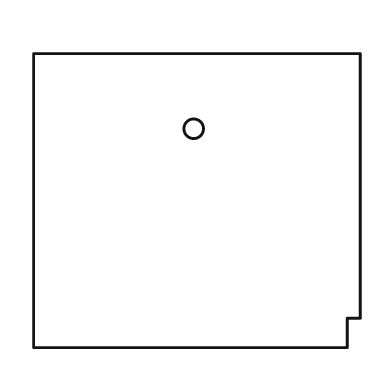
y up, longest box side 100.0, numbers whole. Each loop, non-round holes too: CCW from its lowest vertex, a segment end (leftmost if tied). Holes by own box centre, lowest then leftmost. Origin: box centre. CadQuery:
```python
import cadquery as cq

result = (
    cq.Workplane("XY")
    .moveTo(-50.0, -45.0)
    .lineTo(46.0, -45.0)
    .lineTo(46.0, -36.0)
    .lineTo(50.0, -36.0)
    .lineTo(50.0, 45.0)
    .lineTo(-50.0, 45.0)
    .close()
    .moveTo(-1.0, 22.0)
    .circle(3.0)
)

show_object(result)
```